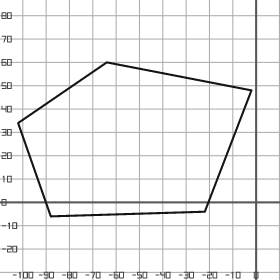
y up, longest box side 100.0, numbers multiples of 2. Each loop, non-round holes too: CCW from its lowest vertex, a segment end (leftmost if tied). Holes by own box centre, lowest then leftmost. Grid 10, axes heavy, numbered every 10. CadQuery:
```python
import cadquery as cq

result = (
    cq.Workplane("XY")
    .moveTo(-88.0, -6.0)
    .lineTo(-22.0, -4.0)
    .lineTo(-2.0, 48.0)
    .lineTo(-64.0, 60.0)
    .lineTo(-102.0, 34.0)
    .close()
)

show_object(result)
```